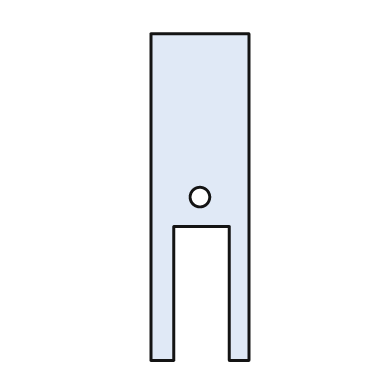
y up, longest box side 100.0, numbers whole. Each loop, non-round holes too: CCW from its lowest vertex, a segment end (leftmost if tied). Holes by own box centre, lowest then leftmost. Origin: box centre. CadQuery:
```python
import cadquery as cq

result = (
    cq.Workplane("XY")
    .moveTo(-15.0, -50.0)
    .lineTo(-8.0, -50.0)
    .lineTo(-8.0, -9.0)
    .lineTo(9.0, -9.0)
    .lineTo(9.0, -50.0)
    .lineTo(15.0, -50.0)
    .lineTo(15.0, 50.0)
    .lineTo(-15.0, 50.0)
    .close()
    .moveTo(0.0, 0.0)
    .circle(3.0)
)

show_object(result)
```